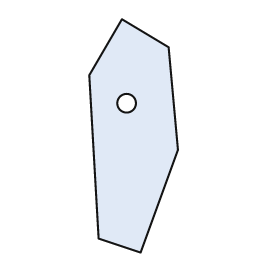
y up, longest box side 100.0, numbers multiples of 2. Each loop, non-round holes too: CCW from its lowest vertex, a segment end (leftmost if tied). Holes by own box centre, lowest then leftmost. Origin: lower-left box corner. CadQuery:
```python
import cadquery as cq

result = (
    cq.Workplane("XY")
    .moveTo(22.0, 0.0)
    .lineTo(38.0, 44.0)
    .lineTo(34.0, 88.0)
    .lineTo(14.0, 100.0)
    .lineTo(0.0, 76.0)
    .lineTo(4.0, 6.0)
    .close()
    .moveTo(16.0, 64.0)
    .circle(4.0)
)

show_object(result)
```